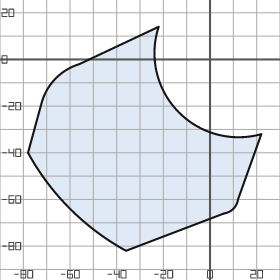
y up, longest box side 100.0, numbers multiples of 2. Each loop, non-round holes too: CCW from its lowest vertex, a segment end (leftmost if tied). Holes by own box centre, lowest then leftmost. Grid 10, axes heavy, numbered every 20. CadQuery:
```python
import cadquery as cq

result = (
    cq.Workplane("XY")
    .moveTo(-36.0, -82.0)
    .lineTo(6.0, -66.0)
    .threePointArc((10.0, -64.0), (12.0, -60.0))
    .lineTo(22.0, -32.0)
    .threePointArc((-14.0, -22.0), (-22.0, 14.0))
    .lineTo(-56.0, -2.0)
    .threePointArc((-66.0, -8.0), (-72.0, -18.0))
    .lineTo(-78.0, -40.0)
    .threePointArc((-60.0, -64.0), (-36.0, -82.0))
    .close()
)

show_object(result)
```